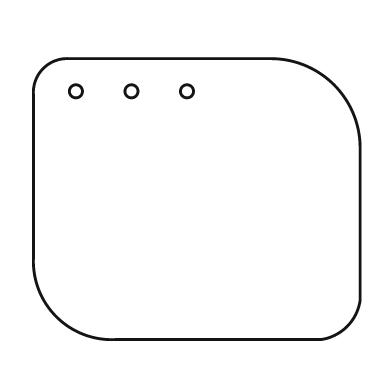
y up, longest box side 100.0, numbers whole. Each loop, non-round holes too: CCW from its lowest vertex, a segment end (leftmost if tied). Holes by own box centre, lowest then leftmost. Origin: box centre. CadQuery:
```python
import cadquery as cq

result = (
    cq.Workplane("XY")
    .moveTo(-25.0, -43.0)
    .lineTo(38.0, -43.0)
    .threePointArc((46.0, -39.0), (50.0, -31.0))
    .lineTo(50.0, 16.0)
    .threePointArc((42.0, 35.0), (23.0, 43.0))
    .lineTo(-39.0, 43.0)
    .threePointArc((-47.0, 40.0), (-50.0, 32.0))
    .lineTo(-50.0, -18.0)
    .threePointArc((-43.0, -36.0), (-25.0, -43.0))
    .close()
    .moveTo(-37.0, 33.0)
    .circle(2.0)
    .moveTo(-20.0, 33.0)
    .circle(2.0)
    .moveTo(-3.0, 33.0)
    .circle(2.0)
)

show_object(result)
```